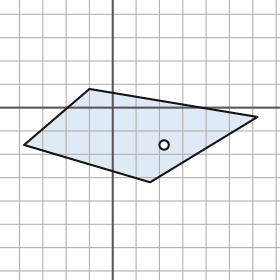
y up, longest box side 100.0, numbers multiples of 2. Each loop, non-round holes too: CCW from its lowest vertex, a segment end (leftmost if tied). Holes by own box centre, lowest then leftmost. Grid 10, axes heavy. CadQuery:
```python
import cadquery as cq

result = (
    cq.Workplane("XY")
    .moveTo(16.0, -32.0)
    .lineTo(62.0, -4.0)
    .lineTo(-10.0, 8.0)
    .lineTo(-38.0, -16.0)
    .close()
    .moveTo(22.0, -16.0)
    .circle(2.0)
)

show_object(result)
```